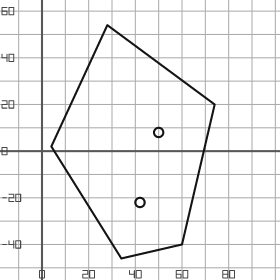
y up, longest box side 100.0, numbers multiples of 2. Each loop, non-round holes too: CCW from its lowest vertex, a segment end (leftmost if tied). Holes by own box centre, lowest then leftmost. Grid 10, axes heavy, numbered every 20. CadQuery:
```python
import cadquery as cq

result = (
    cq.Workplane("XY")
    .moveTo(34.0, -46.0)
    .lineTo(60.0, -40.0)
    .lineTo(74.0, 20.0)
    .lineTo(28.0, 54.0)
    .lineTo(4.0, 2.0)
    .close()
    .moveTo(42.0, -22.0)
    .circle(2.0)
    .moveTo(50.0, 8.0)
    .circle(2.0)
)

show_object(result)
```